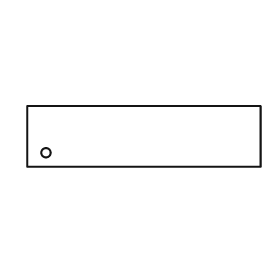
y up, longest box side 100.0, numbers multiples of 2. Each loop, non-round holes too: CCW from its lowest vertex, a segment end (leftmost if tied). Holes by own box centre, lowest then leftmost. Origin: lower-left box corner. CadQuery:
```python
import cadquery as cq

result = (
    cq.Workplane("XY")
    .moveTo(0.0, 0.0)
    .lineTo(100.0, 0.0)
    .lineTo(100.0, 26.0)
    .lineTo(0.0, 26.0)
    .close()
    .moveTo(8.0, 6.0)
    .circle(2.0)
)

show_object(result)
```